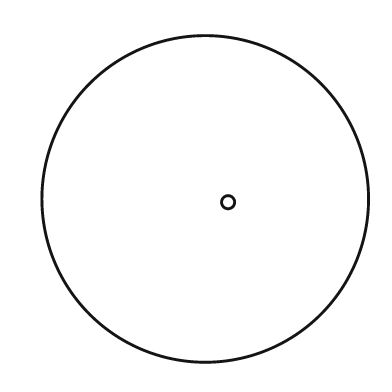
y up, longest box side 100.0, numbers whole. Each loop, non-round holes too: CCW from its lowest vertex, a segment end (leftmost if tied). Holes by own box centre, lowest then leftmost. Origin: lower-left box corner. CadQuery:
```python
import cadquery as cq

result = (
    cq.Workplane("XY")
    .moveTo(50.0, 50.0)
    .circle(50.0)
    .moveTo(57.0, 49.0)
    .circle(2.0)
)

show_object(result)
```